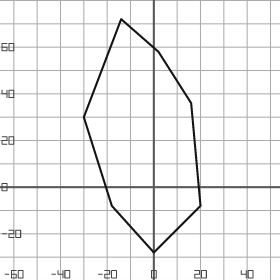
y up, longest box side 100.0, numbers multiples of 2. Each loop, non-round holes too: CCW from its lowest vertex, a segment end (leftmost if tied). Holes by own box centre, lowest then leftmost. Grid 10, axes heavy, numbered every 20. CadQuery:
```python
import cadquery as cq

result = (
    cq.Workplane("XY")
    .moveTo(0.0, -28.0)
    .lineTo(20.0, -8.0)
    .lineTo(16.0, 36.0)
    .lineTo(2.0, 58.0)
    .lineTo(-14.0, 72.0)
    .lineTo(-30.0, 30.0)
    .lineTo(-18.0, -8.0)
    .close()
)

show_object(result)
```